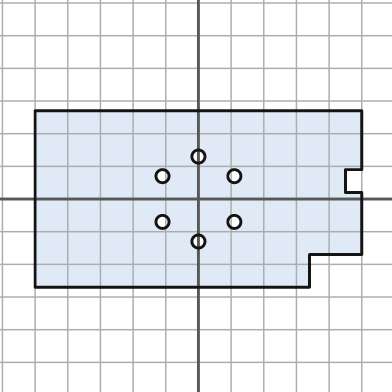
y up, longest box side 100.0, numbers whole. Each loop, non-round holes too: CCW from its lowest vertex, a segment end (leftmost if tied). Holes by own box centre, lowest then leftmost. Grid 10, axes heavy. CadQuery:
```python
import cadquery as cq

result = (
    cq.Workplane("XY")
    .moveTo(-50.0, -27.0)
    .lineTo(34.0, -27.0)
    .lineTo(34.0, -17.0)
    .lineTo(50.0, -17.0)
    .lineTo(50.0, 2.0)
    .lineTo(45.0, 2.0)
    .lineTo(45.0, 9.0)
    .lineTo(50.0, 9.0)
    .lineTo(50.0, 27.0)
    .lineTo(-50.0, 27.0)
    .close()
    .moveTo(0.0, -13.0)
    .circle(2.0)
    .moveTo(-11.0, -7.0)
    .circle(2.0)
    .moveTo(11.0, -7.0)
    .circle(2.0)
    .moveTo(-11.0, 7.0)
    .circle(2.0)
    .moveTo(11.0, 7.0)
    .circle(2.0)
    .moveTo(0.0, 13.0)
    .circle(2.0)
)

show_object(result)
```